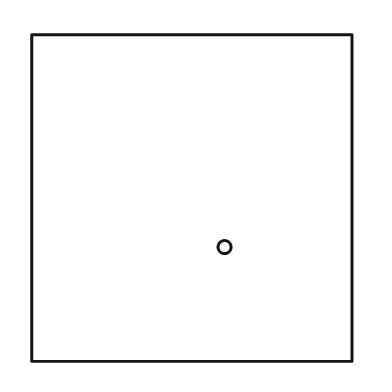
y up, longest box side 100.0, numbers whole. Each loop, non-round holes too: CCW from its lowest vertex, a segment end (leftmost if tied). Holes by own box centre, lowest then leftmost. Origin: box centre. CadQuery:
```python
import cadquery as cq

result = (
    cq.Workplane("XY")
    .moveTo(-49.0, -50.0)
    .lineTo(49.0, -50.0)
    .lineTo(49.0, 50.0)
    .lineTo(-49.0, 50.0)
    .close()
    .moveTo(10.0, -15.0)
    .circle(2.0)
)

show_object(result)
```